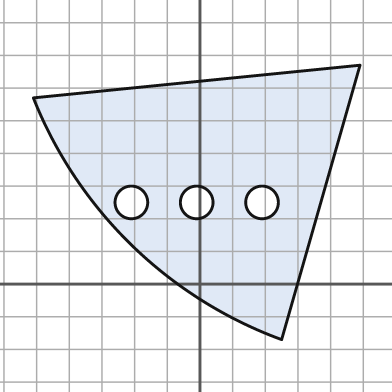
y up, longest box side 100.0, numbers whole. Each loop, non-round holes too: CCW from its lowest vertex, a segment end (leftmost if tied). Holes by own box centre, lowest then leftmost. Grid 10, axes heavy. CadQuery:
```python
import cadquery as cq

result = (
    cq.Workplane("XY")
    .moveTo(25.0, -17.0)
    .lineTo(49.0, 67.0)
    .lineTo(-51.0, 57.0)
    .threePointArc((-21.0, 12.0), (25.0, -17.0))
    .close()
    .moveTo(-21.0, 25.0)
    .circle(5.0)
    .moveTo(-1.0, 25.0)
    .circle(5.0)
    .moveTo(19.0, 25.0)
    .circle(5.0)
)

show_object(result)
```